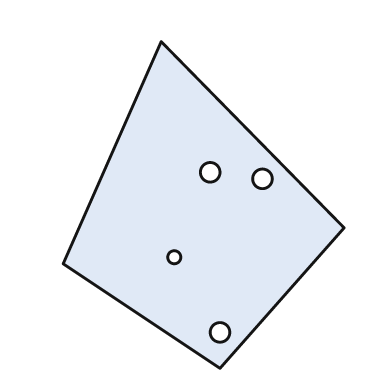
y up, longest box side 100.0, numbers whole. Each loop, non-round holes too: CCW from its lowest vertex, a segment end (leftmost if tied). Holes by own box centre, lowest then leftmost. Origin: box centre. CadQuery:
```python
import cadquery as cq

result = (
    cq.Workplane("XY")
    .moveTo(5.0, -50.0)
    .lineTo(43.0, -7.0)
    .lineTo(-13.0, 50.0)
    .lineTo(-43.0, -18.0)
    .close()
    .moveTo(5.0, -39.0)
    .circle(3.0)
    .moveTo(-9.0, -16.0)
    .circle(2.0)
    .moveTo(18.0, 8.0)
    .circle(3.0)
    .moveTo(2.0, 10.0)
    .circle(3.0)
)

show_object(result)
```